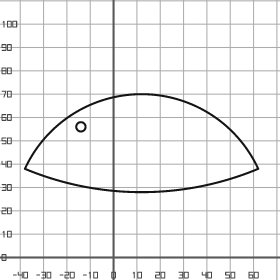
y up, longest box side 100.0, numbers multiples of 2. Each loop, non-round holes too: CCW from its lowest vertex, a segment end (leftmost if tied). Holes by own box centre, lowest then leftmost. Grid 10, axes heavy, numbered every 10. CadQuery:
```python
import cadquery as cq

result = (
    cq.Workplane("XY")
    .moveTo(-38.0, 38.0)
    .threePointArc((12.0, 28.0), (62.0, 38.0))
    .threePointArc((12.0, 70.0), (-38.0, 38.0))
    .close()
    .moveTo(-14.0, 56.0)
    .circle(2.0)
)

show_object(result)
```